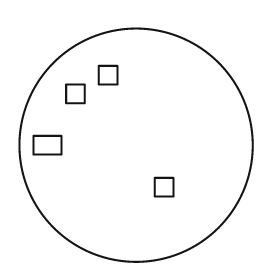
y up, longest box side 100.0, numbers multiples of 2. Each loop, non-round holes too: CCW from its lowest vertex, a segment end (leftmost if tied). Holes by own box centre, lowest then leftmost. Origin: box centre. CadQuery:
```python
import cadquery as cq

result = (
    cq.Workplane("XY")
    .moveTo(0.0, 0.0)
    .circle(50.0)
    .moveTo(8.0, -22.0)
    .lineTo(16.0, -22.0)
    .lineTo(16.0, -14.0)
    .lineTo(8.0, -14.0)
    .close()
    .moveTo(-44.0, -4.0)
    .lineTo(-32.0, -4.0)
    .lineTo(-32.0, 4.0)
    .lineTo(-44.0, 4.0)
    .close()
    .moveTo(-30.0, 18.0)
    .lineTo(-22.0, 18.0)
    .lineTo(-22.0, 26.0)
    .lineTo(-30.0, 26.0)
    .close()
    .moveTo(-16.0, 26.0)
    .lineTo(-8.0, 26.0)
    .lineTo(-8.0, 34.0)
    .lineTo(-16.0, 34.0)
    .close()
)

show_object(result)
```